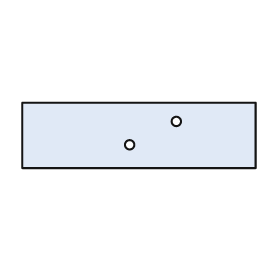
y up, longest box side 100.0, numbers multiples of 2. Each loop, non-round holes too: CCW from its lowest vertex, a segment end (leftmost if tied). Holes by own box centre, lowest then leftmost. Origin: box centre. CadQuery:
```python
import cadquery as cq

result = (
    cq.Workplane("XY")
    .moveTo(-50.0, -14.0)
    .lineTo(50.0, -14.0)
    .lineTo(50.0, 14.0)
    .lineTo(-50.0, 14.0)
    .close()
    .moveTo(-4.0, -4.0)
    .circle(2.0)
    .moveTo(16.0, 6.0)
    .circle(2.0)
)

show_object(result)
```